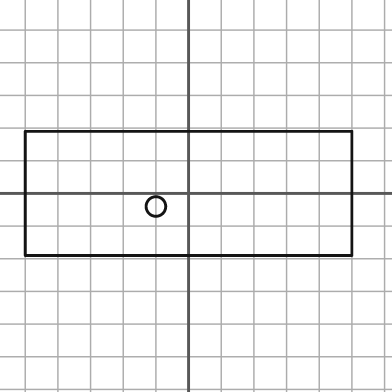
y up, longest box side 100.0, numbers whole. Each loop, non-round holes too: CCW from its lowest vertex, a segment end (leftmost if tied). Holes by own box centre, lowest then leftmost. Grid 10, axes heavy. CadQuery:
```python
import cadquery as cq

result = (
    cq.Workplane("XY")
    .moveTo(-50.0, -19.0)
    .lineTo(50.0, -19.0)
    .lineTo(50.0, 19.0)
    .lineTo(-50.0, 19.0)
    .close()
    .moveTo(-10.0, -4.0)
    .circle(3.0)
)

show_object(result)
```